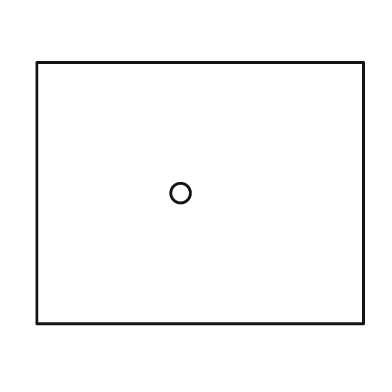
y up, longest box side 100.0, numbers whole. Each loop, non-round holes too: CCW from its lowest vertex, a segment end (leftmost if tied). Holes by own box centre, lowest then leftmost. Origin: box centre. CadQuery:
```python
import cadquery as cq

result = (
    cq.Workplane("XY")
    .moveTo(-50.0, -40.0)
    .lineTo(50.0, -40.0)
    .lineTo(50.0, 40.0)
    .lineTo(-50.0, 40.0)
    .close()
    .moveTo(-6.0, 0.0)
    .circle(3.0)
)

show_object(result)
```